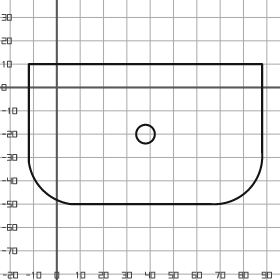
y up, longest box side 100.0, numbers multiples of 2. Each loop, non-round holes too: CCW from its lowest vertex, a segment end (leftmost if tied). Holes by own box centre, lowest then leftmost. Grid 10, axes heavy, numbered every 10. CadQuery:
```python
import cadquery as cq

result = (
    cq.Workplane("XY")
    .moveTo(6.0, -50.0)
    .lineTo(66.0, -50.0)
    .threePointArc((82.0, -44.0), (88.0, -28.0))
    .lineTo(88.0, 10.0)
    .lineTo(-12.0, 10.0)
    .lineTo(-12.0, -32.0)
    .threePointArc((-6.0, -44.0), (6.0, -50.0))
    .close()
    .moveTo(38.0, -20.0)
    .circle(4.0)
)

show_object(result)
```